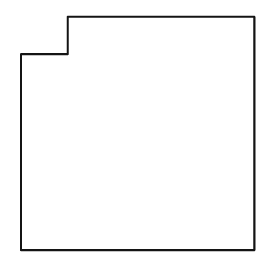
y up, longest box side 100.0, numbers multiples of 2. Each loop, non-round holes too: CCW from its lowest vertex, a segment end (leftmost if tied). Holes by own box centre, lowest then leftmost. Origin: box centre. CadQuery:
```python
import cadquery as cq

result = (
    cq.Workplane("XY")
    .moveTo(-50.0, -50.0)
    .lineTo(50.0, -50.0)
    .lineTo(50.0, 50.0)
    .lineTo(-30.0, 50.0)
    .lineTo(-30.0, 34.0)
    .lineTo(-50.0, 34.0)
    .close()
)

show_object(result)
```